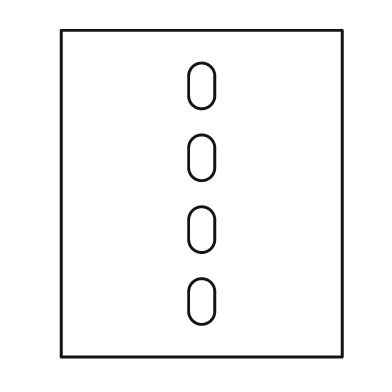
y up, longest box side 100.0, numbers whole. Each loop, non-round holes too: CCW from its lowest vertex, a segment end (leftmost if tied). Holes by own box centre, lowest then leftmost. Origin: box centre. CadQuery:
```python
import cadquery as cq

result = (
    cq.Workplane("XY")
    .moveTo(-43.0, -50.0)
    .lineTo(43.0, -50.0)
    .lineTo(43.0, 50.0)
    .lineTo(-43.0, 50.0)
    .close()
    .moveTo(-4.0, -36.0)
    .threePointArc((0.0, -40.0), (4.0, -36.0))
    .lineTo(4.0, -30.0)
    .threePointArc((0.0, -26.0), (-4.0, -30.0))
    .close()
    .moveTo(-4.0, -14.0)
    .threePointArc((0.0, -18.0), (4.0, -14.0))
    .lineTo(4.0, -8.0)
    .threePointArc((0.0, -4.0), (-4.0, -8.0))
    .close()
    .moveTo(-4.0, 8.0)
    .threePointArc((0.0, 4.0), (4.0, 8.0))
    .lineTo(4.0, 14.0)
    .threePointArc((0.0, 18.0), (-4.0, 14.0))
    .close()
    .moveTo(-4.0, 30.0)
    .threePointArc((0.0, 26.0), (4.0, 30.0))
    .lineTo(4.0, 36.0)
    .threePointArc((0.0, 40.0), (-4.0, 36.0))
    .close()
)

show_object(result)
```